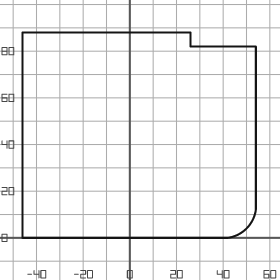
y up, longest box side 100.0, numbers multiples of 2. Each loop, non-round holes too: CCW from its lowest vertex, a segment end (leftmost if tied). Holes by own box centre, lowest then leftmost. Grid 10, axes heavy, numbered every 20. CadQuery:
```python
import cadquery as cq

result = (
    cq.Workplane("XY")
    .moveTo(-46.0, 0.0)
    .lineTo(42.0, 0.0)
    .threePointArc((50.0, 4.0), (54.0, 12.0))
    .lineTo(54.0, 82.0)
    .lineTo(26.0, 82.0)
    .lineTo(26.0, 88.0)
    .lineTo(-46.0, 88.0)
    .close()
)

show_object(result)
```